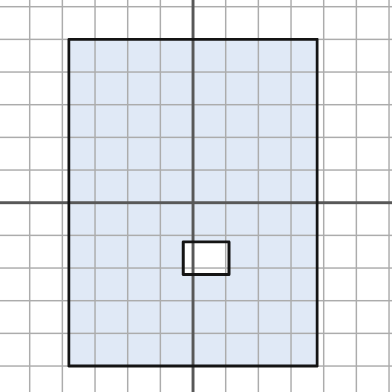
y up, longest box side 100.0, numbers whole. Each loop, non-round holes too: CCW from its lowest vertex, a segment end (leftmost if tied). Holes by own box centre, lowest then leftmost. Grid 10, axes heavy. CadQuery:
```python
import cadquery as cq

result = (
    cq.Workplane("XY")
    .moveTo(-38.0, -50.0)
    .lineTo(38.0, -50.0)
    .lineTo(38.0, 50.0)
    .lineTo(-38.0, 50.0)
    .close()
    .moveTo(-3.0, -22.0)
    .lineTo(11.0, -22.0)
    .lineTo(11.0, -12.0)
    .lineTo(-3.0, -12.0)
    .close()
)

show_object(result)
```